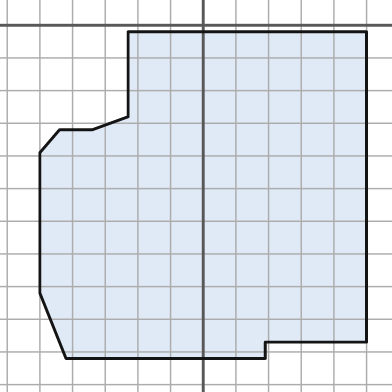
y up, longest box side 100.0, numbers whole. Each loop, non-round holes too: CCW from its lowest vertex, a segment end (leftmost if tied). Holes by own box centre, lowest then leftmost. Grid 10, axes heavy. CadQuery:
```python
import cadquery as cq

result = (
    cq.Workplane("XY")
    .moveTo(-42.0, -102.0)
    .lineTo(19.0, -102.0)
    .lineTo(19.0, -97.0)
    .lineTo(50.0, -97.0)
    .lineTo(50.0, -2.0)
    .lineTo(-23.0, -2.0)
    .lineTo(-23.0, -28.0)
    .lineTo(-34.0, -32.0)
    .lineTo(-44.0, -32.0)
    .lineTo(-50.0, -39.0)
    .lineTo(-50.0, -82.0)
    .close()
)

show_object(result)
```